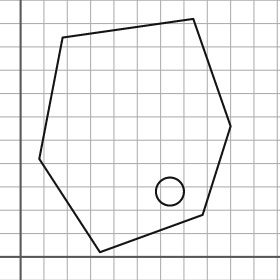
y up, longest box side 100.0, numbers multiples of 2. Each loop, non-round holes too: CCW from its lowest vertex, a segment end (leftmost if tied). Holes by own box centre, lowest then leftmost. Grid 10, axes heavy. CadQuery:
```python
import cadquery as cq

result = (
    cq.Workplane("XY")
    .moveTo(34.0, 2.0)
    .lineTo(78.0, 18.0)
    .lineTo(90.0, 56.0)
    .lineTo(74.0, 102.0)
    .lineTo(18.0, 94.0)
    .lineTo(8.0, 42.0)
    .close()
    .moveTo(64.0, 28.0)
    .circle(6.0)
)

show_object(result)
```